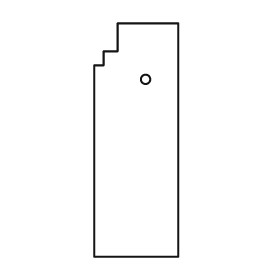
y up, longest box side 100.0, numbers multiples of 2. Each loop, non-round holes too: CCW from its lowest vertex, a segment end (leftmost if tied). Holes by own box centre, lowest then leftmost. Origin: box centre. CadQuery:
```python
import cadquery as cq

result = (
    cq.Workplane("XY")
    .moveTo(-18.0, -50.0)
    .lineTo(18.0, -50.0)
    .lineTo(18.0, 50.0)
    .lineTo(-8.0, 50.0)
    .lineTo(-8.0, 38.0)
    .lineTo(-14.0, 38.0)
    .lineTo(-14.0, 32.0)
    .lineTo(-18.0, 32.0)
    .close()
    .moveTo(4.0, 26.0)
    .circle(2.0)
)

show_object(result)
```